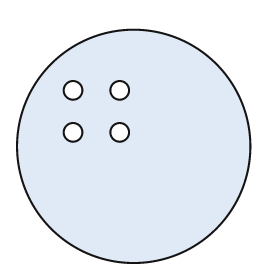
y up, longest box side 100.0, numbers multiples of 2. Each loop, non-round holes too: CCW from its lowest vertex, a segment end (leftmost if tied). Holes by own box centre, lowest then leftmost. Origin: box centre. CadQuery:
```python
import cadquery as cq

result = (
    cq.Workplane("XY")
    .moveTo(0.0, 0.0)
    .circle(50.0)
    .moveTo(-26.0, 6.0)
    .circle(4.0)
    .moveTo(-6.0, 6.0)
    .circle(4.0)
    .moveTo(-26.0, 24.0)
    .circle(4.0)
    .moveTo(-6.0, 24.0)
    .circle(4.0)
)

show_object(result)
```